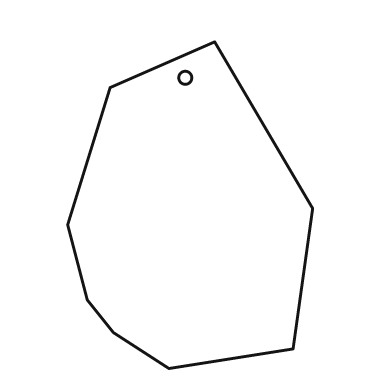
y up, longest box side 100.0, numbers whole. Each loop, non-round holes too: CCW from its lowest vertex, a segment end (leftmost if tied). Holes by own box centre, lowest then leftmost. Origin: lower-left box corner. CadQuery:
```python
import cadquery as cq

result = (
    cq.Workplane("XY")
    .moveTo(31.0, 0.0)
    .lineTo(69.0, 6.0)
    .lineTo(75.0, 49.0)
    .lineTo(45.0, 100.0)
    .lineTo(13.0, 86.0)
    .lineTo(0.0, 44.0)
    .lineTo(6.0, 21.0)
    .lineTo(14.0, 11.0)
    .close()
    .moveTo(36.0, 89.0)
    .circle(2.0)
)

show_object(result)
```